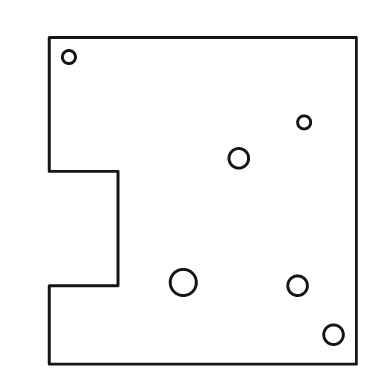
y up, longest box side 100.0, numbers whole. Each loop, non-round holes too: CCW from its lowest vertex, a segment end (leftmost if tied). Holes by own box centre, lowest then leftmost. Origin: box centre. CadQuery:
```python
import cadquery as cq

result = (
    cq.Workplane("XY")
    .moveTo(-47.0, -50.0)
    .lineTo(47.0, -50.0)
    .lineTo(47.0, 50.0)
    .lineTo(-47.0, 50.0)
    .lineTo(-47.0, 9.0)
    .lineTo(-26.0, 9.0)
    .lineTo(-26.0, -26.0)
    .lineTo(-47.0, -26.0)
    .close()
    .moveTo(40.0, -41.0)
    .circle(3.0)
    .moveTo(29.0, -26.0)
    .circle(3.0)
    .moveTo(-6.0, -25.0)
    .circle(4.0)
    .moveTo(11.0, 13.0)
    .circle(3.0)
    .moveTo(31.0, 24.0)
    .circle(2.0)
    .moveTo(-41.0, 44.0)
    .circle(2.0)
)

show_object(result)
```